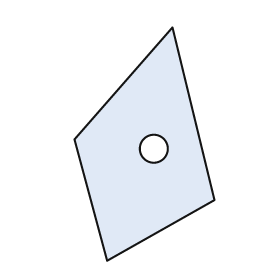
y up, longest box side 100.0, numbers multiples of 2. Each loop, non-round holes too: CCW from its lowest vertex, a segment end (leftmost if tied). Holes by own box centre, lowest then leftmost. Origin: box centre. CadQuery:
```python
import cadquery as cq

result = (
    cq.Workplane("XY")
    .moveTo(-16.0, -50.0)
    .lineTo(30.0, -24.0)
    .lineTo(12.0, 50.0)
    .lineTo(-30.0, 2.0)
    .close()
    .moveTo(4.0, -2.0)
    .circle(6.0)
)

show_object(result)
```